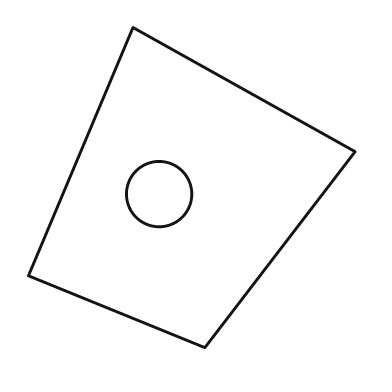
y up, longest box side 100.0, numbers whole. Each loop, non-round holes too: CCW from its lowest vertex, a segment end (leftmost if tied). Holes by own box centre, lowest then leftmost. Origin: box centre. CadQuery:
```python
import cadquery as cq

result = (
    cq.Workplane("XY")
    .moveTo(4.0, -49.0)
    .lineTo(50.0, 11.0)
    .lineTo(-18.0, 49.0)
    .lineTo(-50.0, -27.0)
    .close()
    .moveTo(-10.0, -2.0)
    .circle(10.0)
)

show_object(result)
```